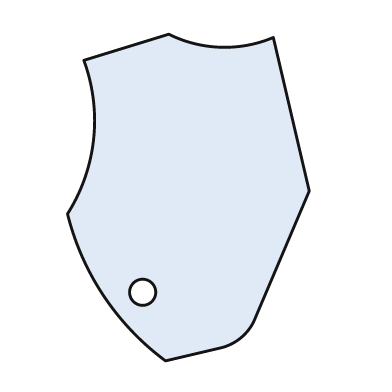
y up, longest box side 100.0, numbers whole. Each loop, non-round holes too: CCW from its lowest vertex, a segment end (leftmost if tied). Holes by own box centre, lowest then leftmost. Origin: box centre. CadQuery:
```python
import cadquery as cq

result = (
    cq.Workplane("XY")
    .moveTo(-7.0, -50.0)
    .lineTo(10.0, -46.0)
    .threePointArc((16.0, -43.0), (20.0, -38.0))
    .lineTo(37.0, 2.0)
    .lineTo(26.0, 49.0)
    .threePointArc((10.0, 46.0), (-6.0, 50.0))
    .lineTo(-32.0, 42.0)
    .threePointArc((-29.0, 18.0), (-37.0, -5.0))
    .threePointArc((-26.0, -30.0), (-7.0, -50.0))
    .close()
    .moveTo(-14.0, -29.0)
    .circle(4.0)
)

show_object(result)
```